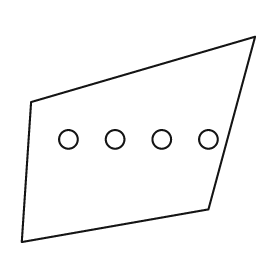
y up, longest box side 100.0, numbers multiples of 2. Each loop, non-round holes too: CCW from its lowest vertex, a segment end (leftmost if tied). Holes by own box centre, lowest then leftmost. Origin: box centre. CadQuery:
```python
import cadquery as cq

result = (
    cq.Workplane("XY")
    .moveTo(-50.0, -44.0)
    .lineTo(30.0, -30.0)
    .lineTo(50.0, 44.0)
    .lineTo(-46.0, 16.0)
    .close()
    .moveTo(-30.0, 0.0)
    .circle(4.0)
    .moveTo(-10.0, 0.0)
    .circle(4.0)
    .moveTo(10.0, 0.0)
    .circle(4.0)
    .moveTo(30.0, 0.0)
    .circle(4.0)
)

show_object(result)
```